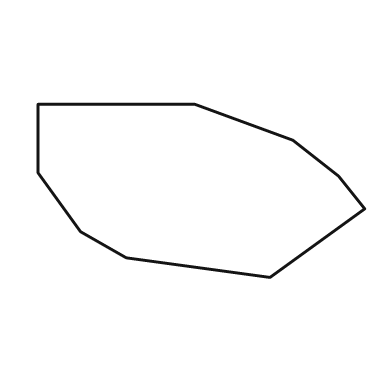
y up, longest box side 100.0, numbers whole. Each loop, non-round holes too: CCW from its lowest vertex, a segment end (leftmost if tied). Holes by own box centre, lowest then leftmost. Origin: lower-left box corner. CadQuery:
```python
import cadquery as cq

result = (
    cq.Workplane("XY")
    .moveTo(71.0, 0.0)
    .lineTo(100.0, 21.0)
    .lineTo(92.0, 31.0)
    .lineTo(78.0, 42.0)
    .lineTo(48.0, 53.0)
    .lineTo(0.0, 53.0)
    .lineTo(0.0, 32.0)
    .lineTo(13.0, 14.0)
    .lineTo(27.0, 6.0)
    .close()
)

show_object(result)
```